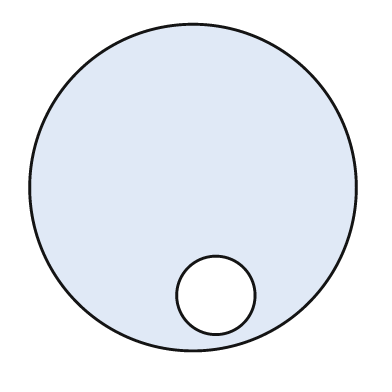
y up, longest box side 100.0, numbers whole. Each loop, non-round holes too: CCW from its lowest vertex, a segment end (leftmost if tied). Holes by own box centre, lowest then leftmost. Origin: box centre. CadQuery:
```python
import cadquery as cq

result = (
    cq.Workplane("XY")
    .moveTo(0.0, 0.0)
    .circle(50.0)
    .moveTo(7.0, -33.0)
    .circle(12.0)
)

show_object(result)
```